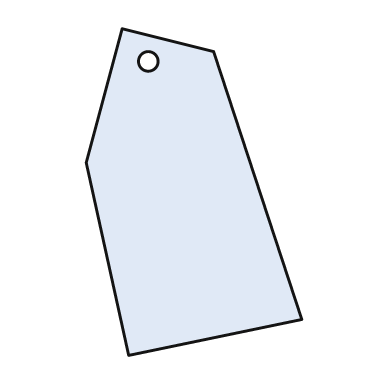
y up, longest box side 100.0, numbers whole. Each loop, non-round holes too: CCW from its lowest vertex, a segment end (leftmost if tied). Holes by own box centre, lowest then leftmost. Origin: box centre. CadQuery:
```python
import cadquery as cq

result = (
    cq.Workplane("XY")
    .moveTo(-20.0, -50.0)
    .lineTo(33.0, -39.0)
    .lineTo(6.0, 43.0)
    .lineTo(-22.0, 50.0)
    .lineTo(-33.0, 9.0)
    .close()
    .moveTo(-14.0, 40.0)
    .circle(3.0)
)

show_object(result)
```